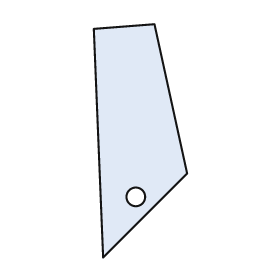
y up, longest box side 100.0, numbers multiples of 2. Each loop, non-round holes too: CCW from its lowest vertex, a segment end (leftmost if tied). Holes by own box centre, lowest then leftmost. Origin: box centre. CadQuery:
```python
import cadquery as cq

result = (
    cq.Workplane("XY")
    .moveTo(-16.0, -50.0)
    .lineTo(20.0, -14.0)
    .lineTo(6.0, 50.0)
    .lineTo(-20.0, 48.0)
    .close()
    .moveTo(-2.0, -24.0)
    .circle(4.0)
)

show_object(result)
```